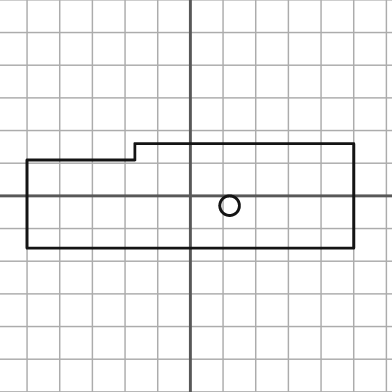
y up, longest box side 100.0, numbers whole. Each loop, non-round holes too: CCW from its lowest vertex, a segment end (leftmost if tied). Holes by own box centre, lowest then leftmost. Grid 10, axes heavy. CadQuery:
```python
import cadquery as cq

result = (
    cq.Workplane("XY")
    .moveTo(-50.0, -16.0)
    .lineTo(50.0, -16.0)
    .lineTo(50.0, 16.0)
    .lineTo(-17.0, 16.0)
    .lineTo(-17.0, 11.0)
    .lineTo(-50.0, 11.0)
    .close()
    .moveTo(12.0, -3.0)
    .circle(3.0)
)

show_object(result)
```